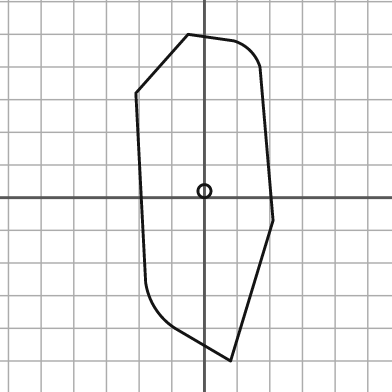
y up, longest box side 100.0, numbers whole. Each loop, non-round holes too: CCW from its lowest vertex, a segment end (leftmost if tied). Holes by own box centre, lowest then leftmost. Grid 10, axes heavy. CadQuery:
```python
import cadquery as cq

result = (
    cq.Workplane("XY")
    .moveTo(8.0, -50.0)
    .lineTo(21.0, -7.0)
    .lineTo(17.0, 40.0)
    .threePointArc((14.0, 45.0), (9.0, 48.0))
    .lineTo(-5.0, 50.0)
    .lineTo(-21.0, 32.0)
    .lineTo(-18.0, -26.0)
    .threePointArc((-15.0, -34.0), (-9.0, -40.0))
    .close()
    .moveTo(0.0, 2.0)
    .circle(2.0)
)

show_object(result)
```